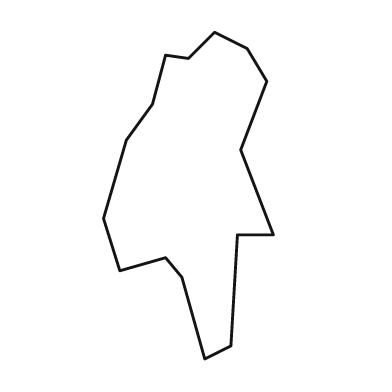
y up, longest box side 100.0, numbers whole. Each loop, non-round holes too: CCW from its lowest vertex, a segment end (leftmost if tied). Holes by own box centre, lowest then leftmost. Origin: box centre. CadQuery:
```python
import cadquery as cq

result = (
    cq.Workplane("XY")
    .moveTo(5.0, -50.0)
    .lineTo(13.0, -46.0)
    .lineTo(15.0, -12.0)
    .lineTo(26.0, -12.0)
    .lineTo(16.0, 14.0)
    .lineTo(24.0, 35.0)
    .lineTo(18.0, 45.0)
    .lineTo(8.0, 50.0)
    .lineTo(0.0, 42.0)
    .lineTo(-7.0, 43.0)
    .lineTo(-11.0, 28.0)
    .lineTo(-19.0, 17.0)
    .lineTo(-26.0, -7.0)
    .lineTo(-21.0, -23.0)
    .lineTo(-7.0, -19.0)
    .lineTo(-2.0, -25.0)
    .close()
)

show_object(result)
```